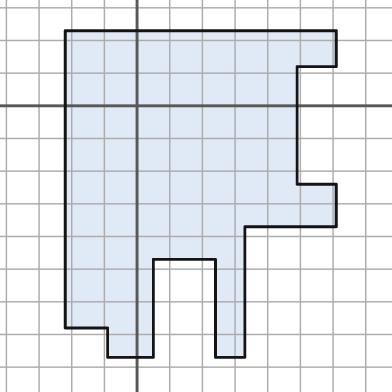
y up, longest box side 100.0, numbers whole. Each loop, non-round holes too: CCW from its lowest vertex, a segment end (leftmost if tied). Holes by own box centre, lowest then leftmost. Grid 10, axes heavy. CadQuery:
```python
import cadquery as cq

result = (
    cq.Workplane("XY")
    .moveTo(-9.0, -77.0)
    .lineTo(5.0, -77.0)
    .lineTo(5.0, -47.0)
    .lineTo(24.0, -47.0)
    .lineTo(24.0, -77.0)
    .lineTo(33.0, -77.0)
    .lineTo(33.0, -37.0)
    .lineTo(61.0, -37.0)
    .lineTo(61.0, -24.0)
    .lineTo(49.0, -24.0)
    .lineTo(49.0, 12.0)
    .lineTo(61.0, 12.0)
    .lineTo(61.0, 23.0)
    .lineTo(-22.0, 23.0)
    .lineTo(-22.0, -68.0)
    .lineTo(-9.0, -68.0)
    .close()
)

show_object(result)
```